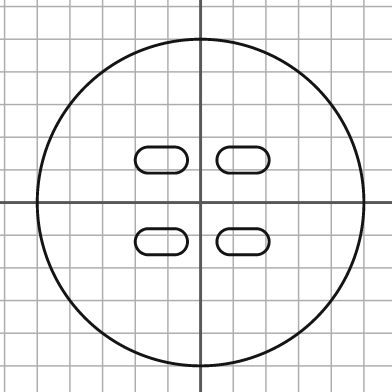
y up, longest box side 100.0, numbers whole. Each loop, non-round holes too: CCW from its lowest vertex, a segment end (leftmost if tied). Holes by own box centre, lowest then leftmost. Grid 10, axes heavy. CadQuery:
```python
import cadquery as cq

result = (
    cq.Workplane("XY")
    .moveTo(0.0, 0.0)
    .circle(50.0)
    .moveTo(-16.0, -16.0)
    .lineTo(-8.0, -16.0)
    .threePointArc((-4.0, -12.0), (-8.0, -8.0))
    .lineTo(-16.0, -8.0)
    .threePointArc((-20.0, -12.0), (-16.0, -16.0))
    .close()
    .moveTo(9.0, -16.0)
    .lineTo(17.0, -16.0)
    .threePointArc((21.0, -12.0), (17.0, -8.0))
    .lineTo(9.0, -8.0)
    .threePointArc((5.0, -12.0), (9.0, -16.0))
    .close()
    .moveTo(-16.0, 9.0)
    .lineTo(-8.0, 9.0)
    .threePointArc((-4.0, 13.0), (-8.0, 17.0))
    .lineTo(-16.0, 17.0)
    .threePointArc((-20.0, 13.0), (-16.0, 9.0))
    .close()
    .moveTo(9.0, 9.0)
    .lineTo(17.0, 9.0)
    .threePointArc((21.0, 13.0), (17.0, 17.0))
    .lineTo(9.0, 17.0)
    .threePointArc((5.0, 13.0), (9.0, 9.0))
    .close()
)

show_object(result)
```